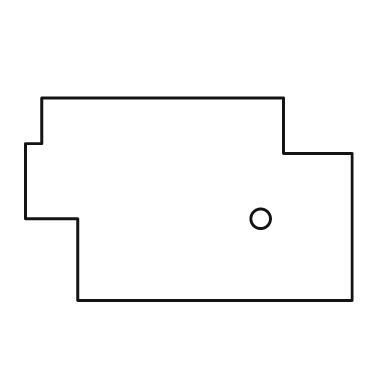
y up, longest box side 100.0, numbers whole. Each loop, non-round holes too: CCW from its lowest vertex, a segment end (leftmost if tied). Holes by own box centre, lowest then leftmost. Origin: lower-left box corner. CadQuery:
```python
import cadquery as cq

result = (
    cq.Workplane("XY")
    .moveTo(16.0, 0.0)
    .lineTo(100.0, 0.0)
    .lineTo(100.0, 45.0)
    .lineTo(79.0, 45.0)
    .lineTo(79.0, 62.0)
    .lineTo(5.0, 62.0)
    .lineTo(5.0, 48.0)
    .lineTo(0.0, 48.0)
    .lineTo(0.0, 25.0)
    .lineTo(16.0, 25.0)
    .close()
    .moveTo(72.0, 25.0)
    .circle(3.0)
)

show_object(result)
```